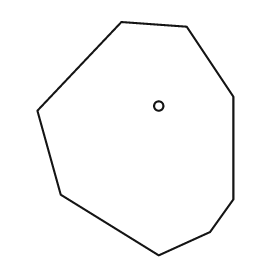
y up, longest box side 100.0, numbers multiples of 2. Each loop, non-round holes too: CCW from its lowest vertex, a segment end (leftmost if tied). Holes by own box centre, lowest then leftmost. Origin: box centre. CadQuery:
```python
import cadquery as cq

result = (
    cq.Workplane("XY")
    .moveTo(10.0, -50.0)
    .lineTo(32.0, -40.0)
    .lineTo(42.0, -26.0)
    .lineTo(42.0, 18.0)
    .lineTo(22.0, 48.0)
    .lineTo(-6.0, 50.0)
    .lineTo(-42.0, 12.0)
    .lineTo(-32.0, -24.0)
    .close()
    .moveTo(10.0, 14.0)
    .circle(2.0)
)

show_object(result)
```